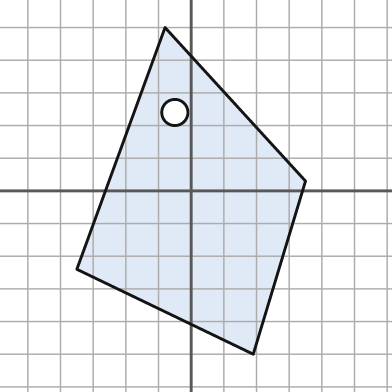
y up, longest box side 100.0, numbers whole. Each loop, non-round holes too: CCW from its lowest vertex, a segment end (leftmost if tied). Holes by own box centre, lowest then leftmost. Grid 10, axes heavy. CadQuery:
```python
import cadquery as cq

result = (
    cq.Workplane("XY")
    .moveTo(19.0, -50.0)
    .lineTo(35.0, 3.0)
    .lineTo(-8.0, 50.0)
    .lineTo(-35.0, -24.0)
    .close()
    .moveTo(-5.0, 24.0)
    .circle(4.0)
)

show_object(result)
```